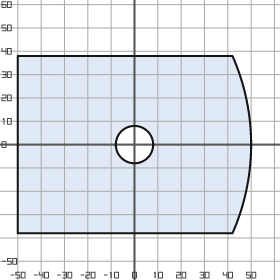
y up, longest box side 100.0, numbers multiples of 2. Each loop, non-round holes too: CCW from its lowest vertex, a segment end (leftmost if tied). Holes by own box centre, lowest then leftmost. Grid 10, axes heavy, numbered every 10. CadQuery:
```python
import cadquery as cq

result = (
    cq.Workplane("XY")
    .moveTo(-50.0, -38.0)
    .lineTo(42.0, -38.0)
    .threePointArc((50.0, 0.0), (42.0, 38.0))
    .lineTo(-50.0, 38.0)
    .close()
    .moveTo(0.0, 0.0)
    .circle(8.0)
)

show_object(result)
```